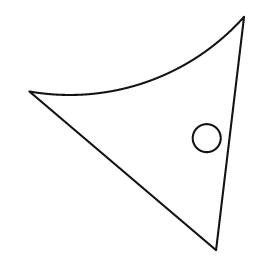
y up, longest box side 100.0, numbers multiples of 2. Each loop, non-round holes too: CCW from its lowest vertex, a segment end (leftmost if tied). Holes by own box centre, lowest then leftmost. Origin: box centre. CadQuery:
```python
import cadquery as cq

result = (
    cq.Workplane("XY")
    .moveTo(34.0, -50.0)
    .lineTo(46.0, 50.0)
    .threePointArc((4.0, 22.0), (-46.0, 18.0))
    .close()
    .moveTo(30.0, -2.0)
    .circle(6.0)
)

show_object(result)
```